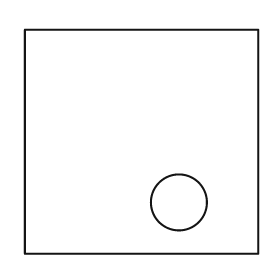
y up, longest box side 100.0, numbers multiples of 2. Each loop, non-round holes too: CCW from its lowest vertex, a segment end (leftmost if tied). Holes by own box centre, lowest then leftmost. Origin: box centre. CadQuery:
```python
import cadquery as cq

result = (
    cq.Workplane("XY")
    .moveTo(-50.0, -48.0)
    .lineTo(50.0, -48.0)
    .lineTo(50.0, 48.0)
    .lineTo(-50.0, 48.0)
    .close()
    .moveTo(16.0, -26.0)
    .circle(12.0)
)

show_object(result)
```